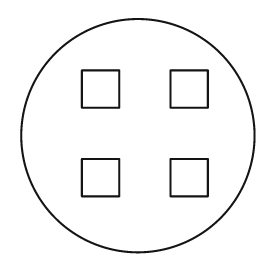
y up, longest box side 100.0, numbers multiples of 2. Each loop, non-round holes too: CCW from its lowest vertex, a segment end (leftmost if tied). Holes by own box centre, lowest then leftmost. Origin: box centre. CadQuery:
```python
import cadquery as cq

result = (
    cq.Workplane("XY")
    .moveTo(0.0, 0.0)
    .circle(50.0)
    .moveTo(-24.0, -26.0)
    .lineTo(-8.0, -26.0)
    .lineTo(-8.0, -10.0)
    .lineTo(-24.0, -10.0)
    .close()
    .moveTo(14.0, -26.0)
    .lineTo(30.0, -26.0)
    .lineTo(30.0, -10.0)
    .lineTo(14.0, -10.0)
    .close()
    .moveTo(-24.0, 12.0)
    .lineTo(-8.0, 12.0)
    .lineTo(-8.0, 28.0)
    .lineTo(-24.0, 28.0)
    .close()
    .moveTo(14.0, 12.0)
    .lineTo(30.0, 12.0)
    .lineTo(30.0, 28.0)
    .lineTo(14.0, 28.0)
    .close()
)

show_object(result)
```